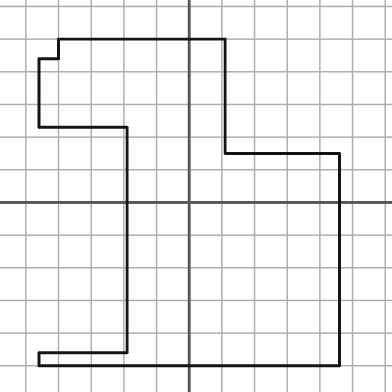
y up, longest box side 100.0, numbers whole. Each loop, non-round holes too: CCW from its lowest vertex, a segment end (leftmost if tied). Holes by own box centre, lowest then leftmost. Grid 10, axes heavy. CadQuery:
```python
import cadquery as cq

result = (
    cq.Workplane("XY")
    .moveTo(-46.0, -50.0)
    .lineTo(46.0, -50.0)
    .lineTo(46.0, 15.0)
    .lineTo(11.0, 15.0)
    .lineTo(11.0, 50.0)
    .lineTo(-40.0, 50.0)
    .lineTo(-40.0, 44.0)
    .lineTo(-46.0, 44.0)
    .lineTo(-46.0, 23.0)
    .lineTo(-19.0, 23.0)
    .lineTo(-19.0, -46.0)
    .lineTo(-46.0, -46.0)
    .close()
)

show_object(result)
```